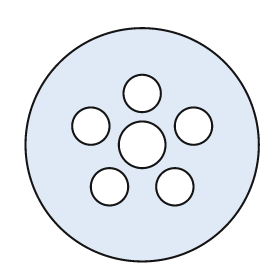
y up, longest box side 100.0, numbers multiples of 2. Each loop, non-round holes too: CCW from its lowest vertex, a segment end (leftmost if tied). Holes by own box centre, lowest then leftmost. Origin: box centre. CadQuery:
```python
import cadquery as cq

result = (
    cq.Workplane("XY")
    .moveTo(0.0, 0.0)
    .circle(50.0)
    .moveTo(-14.0, -18.0)
    .circle(8.0)
    .moveTo(14.0, -18.0)
    .circle(8.0)
    .moveTo(0.0, 0.0)
    .circle(10.0)
    .moveTo(-22.0, 8.0)
    .circle(8.0)
    .moveTo(22.0, 8.0)
    .circle(8.0)
    .moveTo(0.0, 22.0)
    .circle(8.0)
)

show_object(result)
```